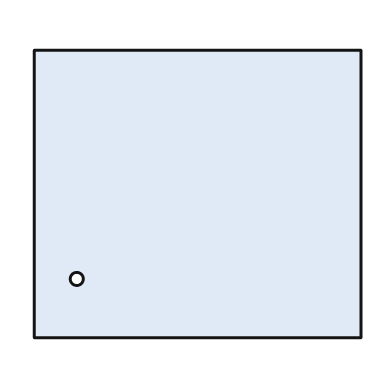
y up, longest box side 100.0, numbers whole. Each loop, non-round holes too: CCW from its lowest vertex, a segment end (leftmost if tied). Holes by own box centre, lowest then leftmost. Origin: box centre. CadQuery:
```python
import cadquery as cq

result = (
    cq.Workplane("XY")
    .moveTo(-50.0, -44.0)
    .lineTo(50.0, -44.0)
    .lineTo(50.0, 44.0)
    .lineTo(-50.0, 44.0)
    .close()
    .moveTo(-37.0, -26.0)
    .circle(2.0)
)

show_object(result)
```